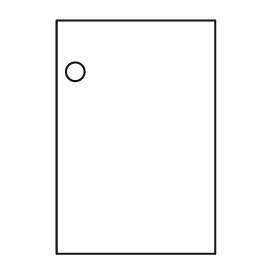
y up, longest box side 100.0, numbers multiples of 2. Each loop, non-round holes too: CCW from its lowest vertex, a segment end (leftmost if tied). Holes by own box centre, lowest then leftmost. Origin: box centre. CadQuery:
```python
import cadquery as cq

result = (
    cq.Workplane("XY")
    .moveTo(-34.0, -50.0)
    .lineTo(34.0, -50.0)
    .lineTo(34.0, 50.0)
    .lineTo(-34.0, 50.0)
    .close()
    .moveTo(-26.0, 28.0)
    .circle(4.0)
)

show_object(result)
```